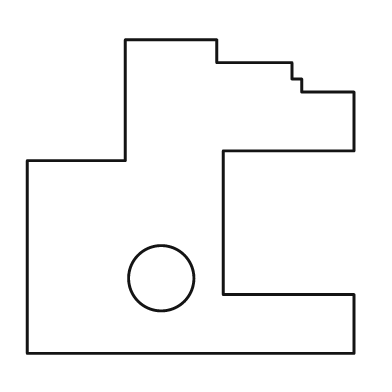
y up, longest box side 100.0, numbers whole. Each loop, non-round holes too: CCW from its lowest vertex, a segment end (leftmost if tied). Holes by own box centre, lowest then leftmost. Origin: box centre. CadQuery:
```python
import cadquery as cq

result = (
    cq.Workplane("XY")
    .moveTo(-50.0, -48.0)
    .lineTo(50.0, -48.0)
    .lineTo(50.0, -30.0)
    .lineTo(10.0, -30.0)
    .lineTo(10.0, 14.0)
    .lineTo(50.0, 14.0)
    .lineTo(50.0, 32.0)
    .lineTo(34.0, 32.0)
    .lineTo(34.0, 36.0)
    .lineTo(31.0, 36.0)
    .lineTo(31.0, 41.0)
    .lineTo(8.0, 41.0)
    .lineTo(8.0, 48.0)
    .lineTo(-20.0, 48.0)
    .lineTo(-20.0, 11.0)
    .lineTo(-50.0, 11.0)
    .close()
    .moveTo(-9.0, -25.0)
    .circle(10.0)
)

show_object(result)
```